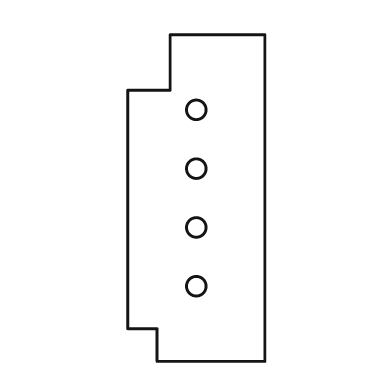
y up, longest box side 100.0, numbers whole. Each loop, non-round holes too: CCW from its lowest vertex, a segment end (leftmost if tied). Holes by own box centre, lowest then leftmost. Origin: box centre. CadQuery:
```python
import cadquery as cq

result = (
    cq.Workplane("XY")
    .moveTo(-12.0, -50.0)
    .lineTo(21.0, -50.0)
    .lineTo(21.0, 50.0)
    .lineTo(-8.0, 50.0)
    .lineTo(-8.0, 33.0)
    .lineTo(-21.0, 33.0)
    .lineTo(-21.0, -40.0)
    .lineTo(-12.0, -40.0)
    .close()
    .moveTo(0.0, -27.0)
    .circle(3.0)
    .moveTo(0.0, -9.0)
    .circle(3.0)
    .moveTo(0.0, 9.0)
    .circle(3.0)
    .moveTo(0.0, 27.0)
    .circle(3.0)
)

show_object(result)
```